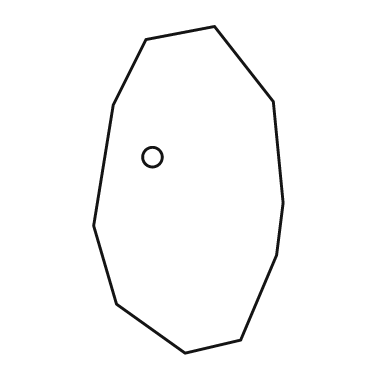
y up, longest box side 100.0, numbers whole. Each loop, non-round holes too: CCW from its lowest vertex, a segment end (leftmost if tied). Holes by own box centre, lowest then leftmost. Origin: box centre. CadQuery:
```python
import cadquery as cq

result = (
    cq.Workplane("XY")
    .moveTo(-1.0, -50.0)
    .lineTo(16.0, -46.0)
    .lineTo(27.0, -20.0)
    .lineTo(29.0, -4.0)
    .lineTo(26.0, 27.0)
    .lineTo(8.0, 50.0)
    .lineTo(-13.0, 46.0)
    .lineTo(-23.0, 26.0)
    .lineTo(-29.0, -11.0)
    .lineTo(-22.0, -35.0)
    .close()
    .moveTo(-11.0, 10.0)
    .circle(3.0)
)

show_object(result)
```